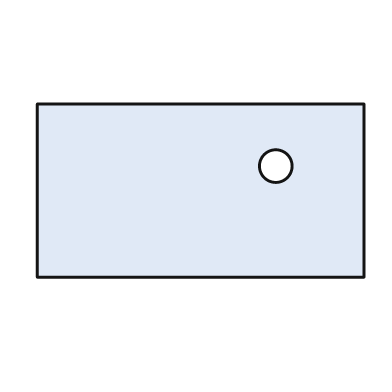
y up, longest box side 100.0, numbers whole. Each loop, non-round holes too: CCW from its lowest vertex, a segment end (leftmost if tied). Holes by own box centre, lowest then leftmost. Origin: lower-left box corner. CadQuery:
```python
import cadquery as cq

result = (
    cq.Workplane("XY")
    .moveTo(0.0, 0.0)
    .lineTo(100.0, 0.0)
    .lineTo(100.0, 53.0)
    .lineTo(0.0, 53.0)
    .close()
    .moveTo(73.0, 34.0)
    .circle(5.0)
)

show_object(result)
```